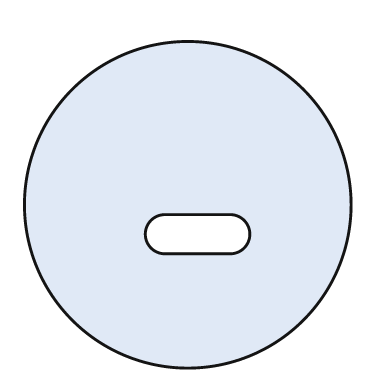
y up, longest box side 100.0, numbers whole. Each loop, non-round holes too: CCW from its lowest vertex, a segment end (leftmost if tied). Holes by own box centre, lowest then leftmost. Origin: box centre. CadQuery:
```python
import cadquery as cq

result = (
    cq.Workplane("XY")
    .moveTo(0.0, 0.0)
    .circle(50.0)
    .moveTo(-7.0, -15.0)
    .lineTo(13.0, -15.0)
    .threePointArc((19.0, -9.0), (13.0, -3.0))
    .lineTo(-7.0, -3.0)
    .threePointArc((-13.0, -9.0), (-7.0, -15.0))
    .close()
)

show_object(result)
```